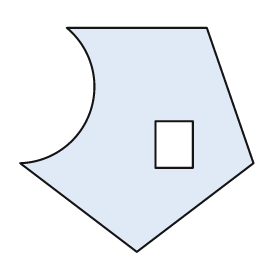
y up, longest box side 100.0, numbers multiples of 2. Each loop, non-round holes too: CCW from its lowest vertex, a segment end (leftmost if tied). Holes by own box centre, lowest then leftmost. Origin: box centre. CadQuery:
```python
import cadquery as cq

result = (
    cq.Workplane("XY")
    .moveTo(0.0, -48.0)
    .lineTo(50.0, -10.0)
    .lineTo(30.0, 48.0)
    .lineTo(-30.0, 48.0)
    .threePointArc((-20.0, 12.0), (-50.0, -10.0))
    .close()
    .moveTo(8.0, -12.0)
    .lineTo(24.0, -12.0)
    .lineTo(24.0, 8.0)
    .lineTo(8.0, 8.0)
    .close()
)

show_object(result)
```